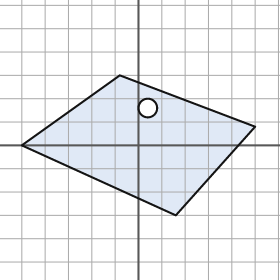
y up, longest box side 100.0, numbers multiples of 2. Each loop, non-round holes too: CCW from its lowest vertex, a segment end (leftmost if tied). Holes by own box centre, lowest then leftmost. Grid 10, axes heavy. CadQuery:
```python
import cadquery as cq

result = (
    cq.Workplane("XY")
    .moveTo(16.0, -30.0)
    .lineTo(50.0, 8.0)
    .lineTo(-8.0, 30.0)
    .lineTo(-50.0, 0.0)
    .close()
    .moveTo(4.0, 16.0)
    .circle(4.0)
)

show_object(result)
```